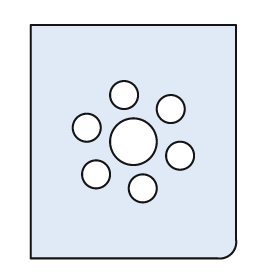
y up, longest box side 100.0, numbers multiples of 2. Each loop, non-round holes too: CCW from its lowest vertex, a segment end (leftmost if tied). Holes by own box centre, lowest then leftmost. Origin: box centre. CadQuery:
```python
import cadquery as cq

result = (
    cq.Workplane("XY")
    .moveTo(-44.0, -50.0)
    .lineTo(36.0, -50.0)
    .threePointArc((42.0, -48.0), (44.0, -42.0))
    .lineTo(44.0, 50.0)
    .lineTo(-44.0, 50.0)
    .close()
    .moveTo(4.0, -20.0)
    .circle(6.0)
    .moveTo(-16.0, -14.0)
    .circle(6.0)
    .moveTo(20.0, -6.0)
    .circle(6.0)
    .moveTo(0.0, 0.0)
    .circle(10.0)
    .moveTo(-20.0, 6.0)
    .circle(6.0)
    .moveTo(16.0, 14.0)
    .circle(6.0)
    .moveTo(-4.0, 20.0)
    .circle(6.0)
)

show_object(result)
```